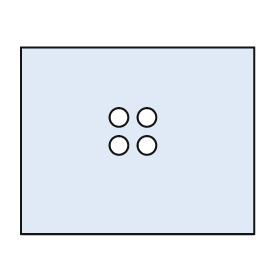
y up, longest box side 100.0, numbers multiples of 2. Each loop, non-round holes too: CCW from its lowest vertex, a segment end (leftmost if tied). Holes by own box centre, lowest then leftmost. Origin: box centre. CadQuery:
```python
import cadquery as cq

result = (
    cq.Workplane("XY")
    .moveTo(-50.0, -40.0)
    .lineTo(50.0, -40.0)
    .lineTo(50.0, 40.0)
    .lineTo(-50.0, 40.0)
    .close()
    .moveTo(-8.0, -2.0)
    .circle(4.0)
    .moveTo(4.0, -2.0)
    .circle(4.0)
    .moveTo(-8.0, 10.0)
    .circle(4.0)
    .moveTo(4.0, 10.0)
    .circle(4.0)
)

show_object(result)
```